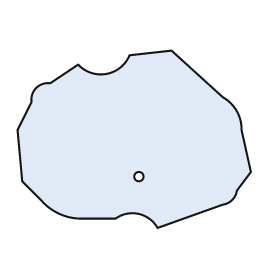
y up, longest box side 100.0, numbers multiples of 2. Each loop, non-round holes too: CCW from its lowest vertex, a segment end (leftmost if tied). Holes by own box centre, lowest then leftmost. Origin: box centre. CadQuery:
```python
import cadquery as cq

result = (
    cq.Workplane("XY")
    .moveTo(10.0, -38.0)
    .lineTo(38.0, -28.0)
    .threePointArc((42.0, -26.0), (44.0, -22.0))
    .lineTo(50.0, -14.0)
    .lineTo(46.0, 4.0)
    .threePointArc((44.0, 12.0), (38.0, 18.0))
    .lineTo(16.0, 38.0)
    .lineTo(-2.0, 36.0)
    .threePointArc((-12.0, 28.0), (-24.0, 32.0))
    .lineTo(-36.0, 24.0)
    .threePointArc((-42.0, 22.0), (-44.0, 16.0))
    .lineTo(-50.0, 4.0)
    .lineTo(-48.0, -18.0)
    .lineTo(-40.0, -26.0)
    .threePointArc((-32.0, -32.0), (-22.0, -34.0))
    .lineTo(-8.0, -34.0)
    .threePointArc((2.0, -32.0), (10.0, -38.0))
    .close()
    .moveTo(2.0, -16.0)
    .circle(2.0)
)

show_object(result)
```